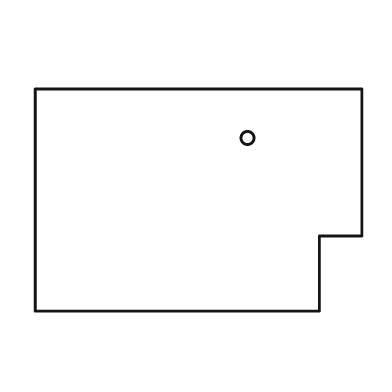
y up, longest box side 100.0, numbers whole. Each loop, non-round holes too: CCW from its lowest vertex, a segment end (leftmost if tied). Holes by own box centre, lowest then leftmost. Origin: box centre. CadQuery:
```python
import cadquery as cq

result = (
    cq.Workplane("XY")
    .moveTo(-50.0, -34.0)
    .lineTo(37.0, -34.0)
    .lineTo(37.0, -11.0)
    .lineTo(50.0, -11.0)
    .lineTo(50.0, 34.0)
    .lineTo(-50.0, 34.0)
    .close()
    .moveTo(15.0, 19.0)
    .circle(2.0)
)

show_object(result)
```